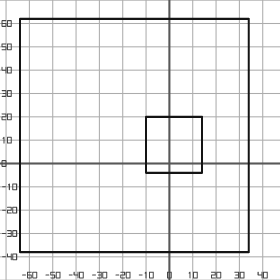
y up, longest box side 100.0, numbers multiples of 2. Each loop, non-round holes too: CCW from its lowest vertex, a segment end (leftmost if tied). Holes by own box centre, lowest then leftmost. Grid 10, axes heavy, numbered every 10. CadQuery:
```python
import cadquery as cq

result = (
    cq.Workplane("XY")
    .moveTo(-64.0, -38.0)
    .lineTo(34.0, -38.0)
    .lineTo(34.0, 62.0)
    .lineTo(-64.0, 62.0)
    .close()
    .moveTo(-10.0, -4.0)
    .lineTo(14.0, -4.0)
    .lineTo(14.0, 20.0)
    .lineTo(-10.0, 20.0)
    .close()
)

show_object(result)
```